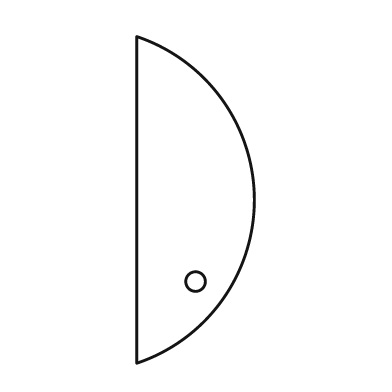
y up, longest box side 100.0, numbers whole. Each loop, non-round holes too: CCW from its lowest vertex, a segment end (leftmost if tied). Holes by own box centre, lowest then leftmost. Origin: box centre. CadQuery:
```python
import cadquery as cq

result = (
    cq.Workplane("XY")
    .moveTo(-18.0, -50.0)
    .threePointArc((18.0, 0.0), (-18.0, 50.0))
    .close()
    .moveTo(0.0, -25.0)
    .circle(3.0)
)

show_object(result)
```